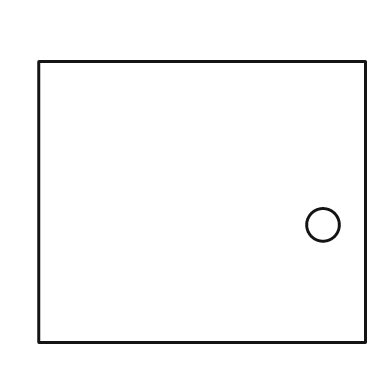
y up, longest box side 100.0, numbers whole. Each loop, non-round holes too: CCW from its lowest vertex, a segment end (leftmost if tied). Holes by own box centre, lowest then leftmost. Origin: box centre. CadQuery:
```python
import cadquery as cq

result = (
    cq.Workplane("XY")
    .moveTo(-50.0, -43.0)
    .lineTo(50.0, -43.0)
    .lineTo(50.0, 43.0)
    .lineTo(-50.0, 43.0)
    .close()
    .moveTo(37.0, -7.0)
    .circle(5.0)
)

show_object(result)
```